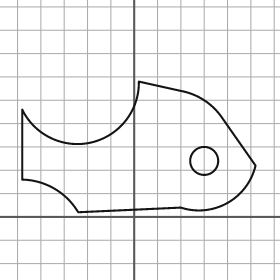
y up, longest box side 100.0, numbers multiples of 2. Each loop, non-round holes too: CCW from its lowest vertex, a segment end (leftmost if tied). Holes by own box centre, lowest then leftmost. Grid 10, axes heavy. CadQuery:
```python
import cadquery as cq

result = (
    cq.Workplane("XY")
    .moveTo(-24.0, 2.0)
    .lineTo(20.0, 4.0)
    .threePointArc((40.0, 6.0), (52.0, 22.0))
    .lineTo(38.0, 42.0)
    .threePointArc((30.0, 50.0), (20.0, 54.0))
    .lineTo(2.0, 58.0)
    .threePointArc((-18.0, 32.0), (-48.0, 46.0))
    .lineTo(-48.0, 16.0)
    .threePointArc((-34.0, 12.0), (-24.0, 2.0))
    .close()
    .moveTo(30.0, 24.0)
    .circle(6.0)
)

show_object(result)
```